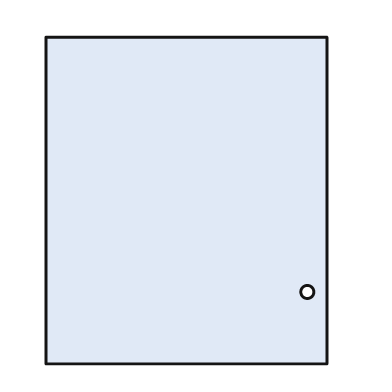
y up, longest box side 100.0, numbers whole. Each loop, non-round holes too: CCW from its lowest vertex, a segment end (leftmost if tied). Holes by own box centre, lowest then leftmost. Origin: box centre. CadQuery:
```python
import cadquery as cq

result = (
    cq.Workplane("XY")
    .moveTo(-43.0, -50.0)
    .lineTo(43.0, -50.0)
    .lineTo(43.0, 50.0)
    .lineTo(-43.0, 50.0)
    .close()
    .moveTo(37.0, -28.0)
    .circle(2.0)
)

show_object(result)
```